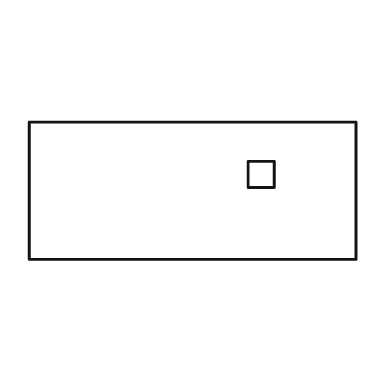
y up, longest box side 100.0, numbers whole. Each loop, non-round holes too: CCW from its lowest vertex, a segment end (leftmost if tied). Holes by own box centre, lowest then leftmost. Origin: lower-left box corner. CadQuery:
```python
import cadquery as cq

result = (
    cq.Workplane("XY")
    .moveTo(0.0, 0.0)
    .lineTo(100.0, 0.0)
    .lineTo(100.0, 42.0)
    .lineTo(0.0, 42.0)
    .close()
    .moveTo(67.0, 22.0)
    .lineTo(75.0, 22.0)
    .lineTo(75.0, 30.0)
    .lineTo(67.0, 30.0)
    .close()
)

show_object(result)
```